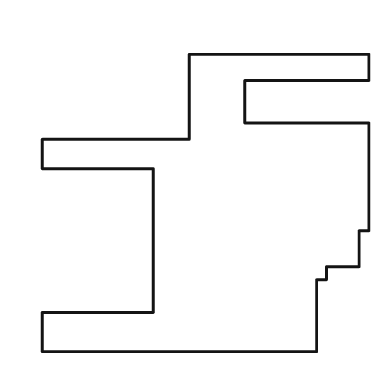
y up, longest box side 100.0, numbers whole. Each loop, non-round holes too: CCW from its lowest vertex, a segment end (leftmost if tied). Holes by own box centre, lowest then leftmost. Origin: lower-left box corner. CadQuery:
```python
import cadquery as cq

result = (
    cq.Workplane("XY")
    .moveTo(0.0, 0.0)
    .lineTo(84.0, 0.0)
    .lineTo(84.0, 22.0)
    .lineTo(87.0, 22.0)
    .lineTo(87.0, 26.0)
    .lineTo(97.0, 26.0)
    .lineTo(97.0, 37.0)
    .lineTo(100.0, 37.0)
    .lineTo(100.0, 70.0)
    .lineTo(62.0, 70.0)
    .lineTo(62.0, 83.0)
    .lineTo(100.0, 83.0)
    .lineTo(100.0, 91.0)
    .lineTo(45.0, 91.0)
    .lineTo(45.0, 65.0)
    .lineTo(0.0, 65.0)
    .lineTo(0.0, 56.0)
    .lineTo(34.0, 56.0)
    .lineTo(34.0, 12.0)
    .lineTo(0.0, 12.0)
    .close()
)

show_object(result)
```